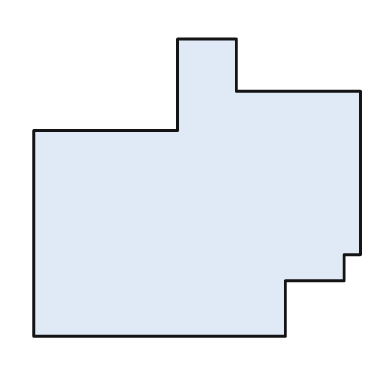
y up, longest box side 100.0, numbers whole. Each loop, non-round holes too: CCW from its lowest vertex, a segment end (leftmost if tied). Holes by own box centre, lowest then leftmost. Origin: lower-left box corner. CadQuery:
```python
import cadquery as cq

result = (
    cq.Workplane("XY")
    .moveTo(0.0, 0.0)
    .lineTo(77.0, 0.0)
    .lineTo(77.0, 17.0)
    .lineTo(95.0, 17.0)
    .lineTo(95.0, 25.0)
    .lineTo(100.0, 25.0)
    .lineTo(100.0, 75.0)
    .lineTo(62.0, 75.0)
    .lineTo(62.0, 91.0)
    .lineTo(44.0, 91.0)
    .lineTo(44.0, 63.0)
    .lineTo(0.0, 63.0)
    .close()
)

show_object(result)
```